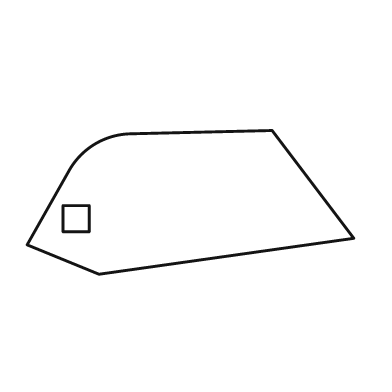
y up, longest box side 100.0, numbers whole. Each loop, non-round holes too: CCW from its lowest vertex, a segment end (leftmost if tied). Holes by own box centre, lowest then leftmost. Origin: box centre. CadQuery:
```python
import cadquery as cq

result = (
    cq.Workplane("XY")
    .moveTo(-28.0, -22.0)
    .lineTo(50.0, -11.0)
    .lineTo(25.0, 22.0)
    .lineTo(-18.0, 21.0)
    .threePointArc((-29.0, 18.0), (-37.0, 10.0))
    .lineTo(-50.0, -13.0)
    .close()
    .moveTo(-39.0, -9.0)
    .lineTo(-31.0, -9.0)
    .lineTo(-31.0, -1.0)
    .lineTo(-39.0, -1.0)
    .close()
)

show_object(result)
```